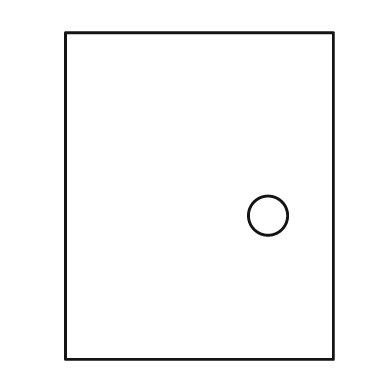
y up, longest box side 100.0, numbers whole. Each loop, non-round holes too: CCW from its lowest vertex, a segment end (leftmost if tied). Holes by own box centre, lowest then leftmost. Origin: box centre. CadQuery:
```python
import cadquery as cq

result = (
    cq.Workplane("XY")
    .moveTo(-41.0, -50.0)
    .lineTo(41.0, -50.0)
    .lineTo(41.0, 50.0)
    .lineTo(-41.0, 50.0)
    .close()
    .moveTo(21.0, -6.0)
    .circle(6.0)
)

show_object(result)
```